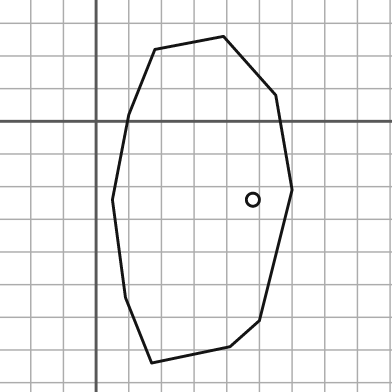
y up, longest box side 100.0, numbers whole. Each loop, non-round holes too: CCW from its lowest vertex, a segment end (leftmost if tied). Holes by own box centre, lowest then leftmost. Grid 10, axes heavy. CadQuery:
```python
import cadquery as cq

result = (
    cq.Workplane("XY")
    .moveTo(17.0, -74.0)
    .lineTo(41.0, -69.0)
    .lineTo(50.0, -61.0)
    .lineTo(60.0, -21.0)
    .lineTo(55.0, 8.0)
    .lineTo(39.0, 26.0)
    .lineTo(18.0, 22.0)
    .lineTo(10.0, 2.0)
    .lineTo(5.0, -24.0)
    .lineTo(9.0, -54.0)
    .close()
    .moveTo(48.0, -24.0)
    .circle(2.0)
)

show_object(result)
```